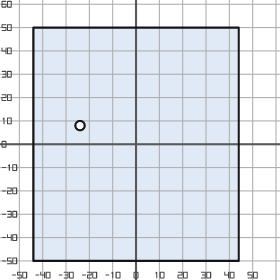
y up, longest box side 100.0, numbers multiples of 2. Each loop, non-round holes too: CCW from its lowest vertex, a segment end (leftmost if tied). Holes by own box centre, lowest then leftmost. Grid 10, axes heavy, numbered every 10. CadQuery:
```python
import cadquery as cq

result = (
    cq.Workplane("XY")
    .moveTo(-44.0, -50.0)
    .lineTo(44.0, -50.0)
    .lineTo(44.0, 50.0)
    .lineTo(-44.0, 50.0)
    .close()
    .moveTo(-24.0, 8.0)
    .circle(2.0)
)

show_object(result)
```